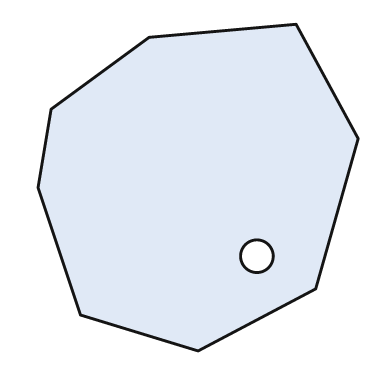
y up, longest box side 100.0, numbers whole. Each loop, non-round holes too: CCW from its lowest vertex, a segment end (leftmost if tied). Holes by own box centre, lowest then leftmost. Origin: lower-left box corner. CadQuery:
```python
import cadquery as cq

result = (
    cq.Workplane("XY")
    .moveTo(49.0, 0.0)
    .lineTo(85.0, 19.0)
    .lineTo(98.0, 65.0)
    .lineTo(79.0, 100.0)
    .lineTo(34.0, 96.0)
    .lineTo(4.0, 74.0)
    .lineTo(0.0, 50.0)
    .lineTo(13.0, 11.0)
    .close()
    .moveTo(67.0, 29.0)
    .circle(5.0)
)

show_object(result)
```